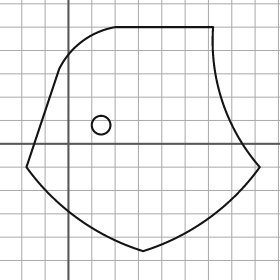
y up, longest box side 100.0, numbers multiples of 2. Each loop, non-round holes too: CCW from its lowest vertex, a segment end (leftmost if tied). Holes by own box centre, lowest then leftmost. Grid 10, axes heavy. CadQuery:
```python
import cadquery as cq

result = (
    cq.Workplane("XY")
    .moveTo(32.0, -46.0)
    .threePointArc((60.0, -32.0), (82.0, -10.0))
    .threePointArc((66.0, 18.0), (62.0, 50.0))
    .lineTo(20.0, 50.0)
    .threePointArc((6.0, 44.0), (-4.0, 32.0))
    .lineTo(-18.0, -10.0)
    .threePointArc((4.0, -32.0), (32.0, -46.0))
    .close()
    .moveTo(14.0, 8.0)
    .circle(4.0)
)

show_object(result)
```